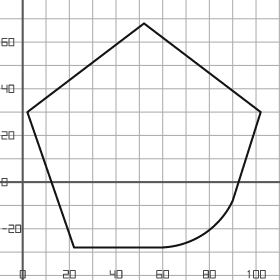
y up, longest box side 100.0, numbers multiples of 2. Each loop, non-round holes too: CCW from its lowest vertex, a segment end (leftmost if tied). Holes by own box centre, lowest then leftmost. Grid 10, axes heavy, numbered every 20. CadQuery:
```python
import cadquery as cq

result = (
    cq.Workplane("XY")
    .moveTo(22.0, -28.0)
    .lineTo(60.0, -28.0)
    .threePointArc((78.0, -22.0), (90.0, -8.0))
    .lineTo(102.0, 30.0)
    .lineTo(52.0, 68.0)
    .lineTo(2.0, 30.0)
    .close()
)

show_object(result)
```